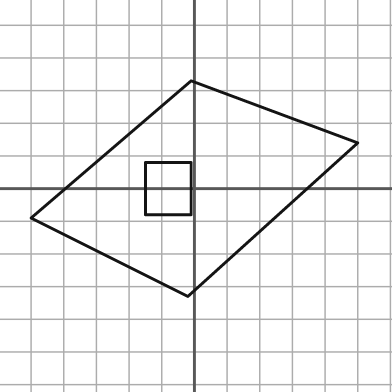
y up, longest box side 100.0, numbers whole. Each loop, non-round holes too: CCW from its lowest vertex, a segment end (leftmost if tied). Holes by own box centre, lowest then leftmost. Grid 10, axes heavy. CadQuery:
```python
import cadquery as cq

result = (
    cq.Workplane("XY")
    .moveTo(-2.0, -33.0)
    .lineTo(50.0, 14.0)
    .lineTo(-1.0, 33.0)
    .lineTo(-50.0, -9.0)
    .close()
    .moveTo(-15.0, -8.0)
    .lineTo(-1.0, -8.0)
    .lineTo(-1.0, 8.0)
    .lineTo(-15.0, 8.0)
    .close()
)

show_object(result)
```